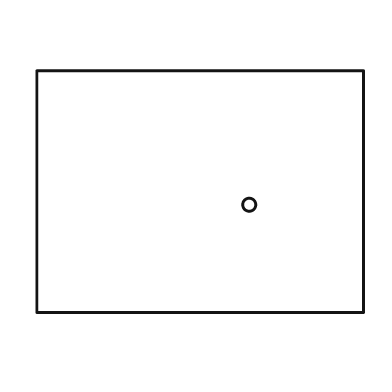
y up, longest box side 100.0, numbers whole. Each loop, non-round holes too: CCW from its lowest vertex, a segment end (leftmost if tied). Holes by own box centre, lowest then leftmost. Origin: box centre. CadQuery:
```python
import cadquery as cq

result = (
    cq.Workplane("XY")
    .moveTo(-50.0, -37.0)
    .lineTo(50.0, -37.0)
    .lineTo(50.0, 37.0)
    .lineTo(-50.0, 37.0)
    .close()
    .moveTo(15.0, -4.0)
    .circle(2.0)
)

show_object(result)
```